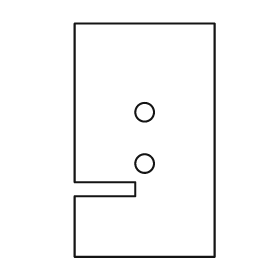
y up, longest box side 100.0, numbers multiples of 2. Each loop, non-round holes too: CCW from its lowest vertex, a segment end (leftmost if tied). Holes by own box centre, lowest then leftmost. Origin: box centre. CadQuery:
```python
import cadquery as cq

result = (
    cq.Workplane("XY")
    .moveTo(-30.0, -50.0)
    .lineTo(30.0, -50.0)
    .lineTo(30.0, 50.0)
    .lineTo(-30.0, 50.0)
    .lineTo(-30.0, -18.0)
    .lineTo(-4.0, -18.0)
    .lineTo(-4.0, -24.0)
    .lineTo(-30.0, -24.0)
    .close()
    .moveTo(0.0, -10.0)
    .circle(4.0)
    .moveTo(0.0, 12.0)
    .circle(4.0)
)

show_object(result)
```